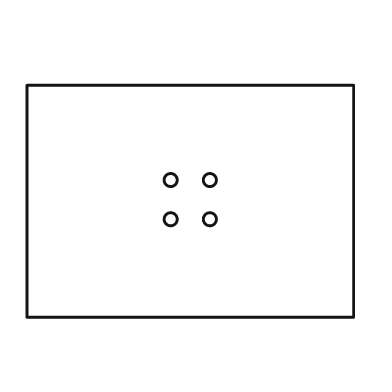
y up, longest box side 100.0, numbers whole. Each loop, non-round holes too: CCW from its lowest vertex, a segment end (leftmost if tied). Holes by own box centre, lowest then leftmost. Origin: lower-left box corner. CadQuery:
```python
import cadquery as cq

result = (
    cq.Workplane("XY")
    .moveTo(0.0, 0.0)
    .lineTo(100.0, 0.0)
    .lineTo(100.0, 71.0)
    .lineTo(0.0, 71.0)
    .close()
    .moveTo(44.0, 30.0)
    .circle(2.0)
    .moveTo(56.0, 30.0)
    .circle(2.0)
    .moveTo(44.0, 42.0)
    .circle(2.0)
    .moveTo(56.0, 42.0)
    .circle(2.0)
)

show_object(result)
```